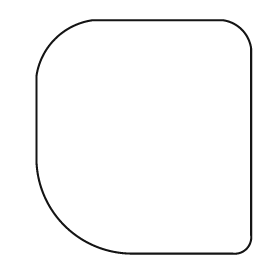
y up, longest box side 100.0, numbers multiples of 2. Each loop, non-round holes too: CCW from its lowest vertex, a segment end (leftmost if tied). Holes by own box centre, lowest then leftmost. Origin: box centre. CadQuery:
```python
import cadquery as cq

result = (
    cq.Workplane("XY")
    .moveTo(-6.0, -50.0)
    .lineTo(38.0, -50.0)
    .threePointArc((44.0, -48.0), (46.0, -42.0))
    .lineTo(46.0, 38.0)
    .threePointArc((42.0, 46.0), (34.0, 50.0))
    .lineTo(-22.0, 50.0)
    .threePointArc((-38.0, 42.0), (-46.0, 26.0))
    .lineTo(-46.0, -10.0)
    .threePointArc((-34.0, -38.0), (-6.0, -50.0))
    .close()
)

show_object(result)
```